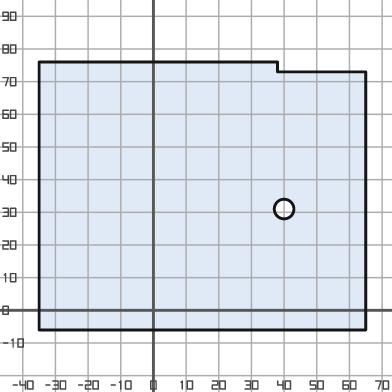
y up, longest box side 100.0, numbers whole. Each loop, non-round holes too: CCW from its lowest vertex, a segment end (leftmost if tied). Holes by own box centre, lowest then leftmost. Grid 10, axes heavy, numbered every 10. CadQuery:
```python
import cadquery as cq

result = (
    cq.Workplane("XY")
    .moveTo(-35.0, -6.0)
    .lineTo(65.0, -6.0)
    .lineTo(65.0, 73.0)
    .lineTo(38.0, 73.0)
    .lineTo(38.0, 76.0)
    .lineTo(-35.0, 76.0)
    .close()
    .moveTo(40.0, 31.0)
    .circle(3.0)
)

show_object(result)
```